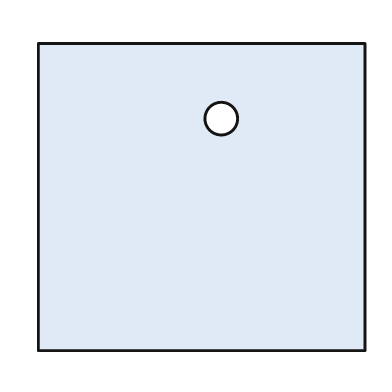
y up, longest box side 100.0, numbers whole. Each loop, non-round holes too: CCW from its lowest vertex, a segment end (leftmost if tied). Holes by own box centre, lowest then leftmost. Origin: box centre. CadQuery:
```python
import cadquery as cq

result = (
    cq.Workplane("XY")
    .moveTo(-50.0, -47.0)
    .lineTo(50.0, -47.0)
    .lineTo(50.0, 47.0)
    .lineTo(-50.0, 47.0)
    .close()
    .moveTo(6.0, 24.0)
    .circle(5.0)
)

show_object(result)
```